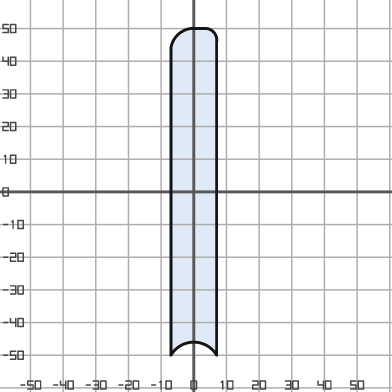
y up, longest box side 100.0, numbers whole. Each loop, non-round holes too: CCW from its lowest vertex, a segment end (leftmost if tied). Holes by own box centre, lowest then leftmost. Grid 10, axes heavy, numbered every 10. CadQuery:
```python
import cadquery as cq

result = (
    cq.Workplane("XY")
    .moveTo(-7.0, -50.0)
    .threePointArc((0.0, -46.0), (7.0, -50.0))
    .lineTo(7.0, 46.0)
    .threePointArc((6.0, 49.0), (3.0, 50.0))
    .lineTo(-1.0, 50.0)
    .threePointArc((-5.0, 48.0), (-7.0, 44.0))
    .close()
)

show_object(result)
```